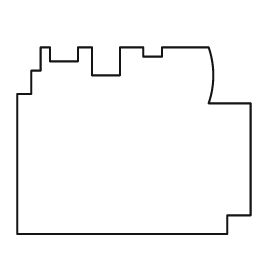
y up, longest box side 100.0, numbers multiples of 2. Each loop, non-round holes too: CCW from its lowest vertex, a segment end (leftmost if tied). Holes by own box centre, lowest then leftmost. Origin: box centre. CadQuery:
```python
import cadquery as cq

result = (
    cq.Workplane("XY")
    .moveTo(-50.0, -40.0)
    .lineTo(40.0, -40.0)
    .lineTo(40.0, -32.0)
    .lineTo(50.0, -32.0)
    .lineTo(50.0, 16.0)
    .lineTo(32.0, 16.0)
    .threePointArc((34.0, 28.0), (32.0, 40.0))
    .lineTo(12.0, 40.0)
    .lineTo(12.0, 36.0)
    .lineTo(4.0, 36.0)
    .lineTo(4.0, 40.0)
    .lineTo(-6.0, 40.0)
    .lineTo(-6.0, 28.0)
    .lineTo(-18.0, 28.0)
    .lineTo(-18.0, 40.0)
    .lineTo(-24.0, 40.0)
    .lineTo(-24.0, 34.0)
    .lineTo(-36.0, 34.0)
    .lineTo(-36.0, 40.0)
    .lineTo(-40.0, 40.0)
    .lineTo(-40.0, 30.0)
    .lineTo(-44.0, 30.0)
    .lineTo(-44.0, 20.0)
    .lineTo(-50.0, 20.0)
    .close()
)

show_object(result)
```